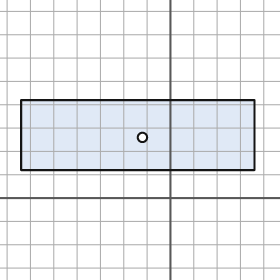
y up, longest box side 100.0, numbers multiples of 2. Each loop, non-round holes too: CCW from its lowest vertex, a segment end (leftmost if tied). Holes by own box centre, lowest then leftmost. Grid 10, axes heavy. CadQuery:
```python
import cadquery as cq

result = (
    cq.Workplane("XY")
    .moveTo(-64.0, 12.0)
    .lineTo(36.0, 12.0)
    .lineTo(36.0, 42.0)
    .lineTo(-64.0, 42.0)
    .close()
    .moveTo(-12.0, 26.0)
    .circle(2.0)
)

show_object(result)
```